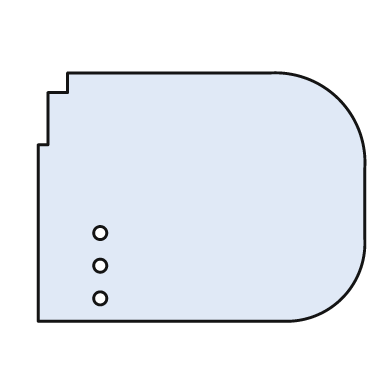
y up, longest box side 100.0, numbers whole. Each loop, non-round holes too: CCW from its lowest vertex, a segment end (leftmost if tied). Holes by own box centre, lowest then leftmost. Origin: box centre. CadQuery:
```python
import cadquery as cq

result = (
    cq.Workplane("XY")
    .moveTo(-50.0, -38.0)
    .lineTo(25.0, -38.0)
    .threePointArc((43.0, -31.0), (50.0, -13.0))
    .lineTo(50.0, 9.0)
    .threePointArc((42.0, 30.0), (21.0, 38.0))
    .lineTo(-41.0, 38.0)
    .lineTo(-41.0, 32.0)
    .lineTo(-47.0, 32.0)
    .lineTo(-47.0, 16.0)
    .lineTo(-50.0, 16.0)
    .close()
    .moveTo(-31.0, -31.0)
    .circle(2.0)
    .moveTo(-31.0, -21.0)
    .circle(2.0)
    .moveTo(-31.0, -11.0)
    .circle(2.0)
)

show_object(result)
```